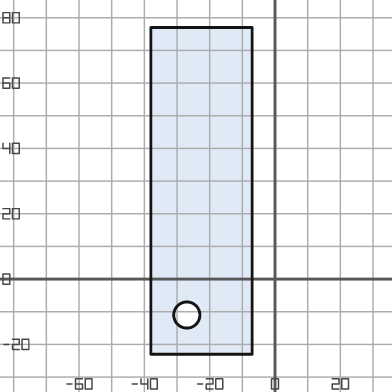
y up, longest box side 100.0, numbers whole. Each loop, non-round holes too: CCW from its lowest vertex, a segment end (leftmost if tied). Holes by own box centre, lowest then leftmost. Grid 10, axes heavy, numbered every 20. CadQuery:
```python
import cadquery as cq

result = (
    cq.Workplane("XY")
    .moveTo(-38.0, -23.0)
    .lineTo(-7.0, -23.0)
    .lineTo(-7.0, 77.0)
    .lineTo(-38.0, 77.0)
    .close()
    .moveTo(-27.0, -11.0)
    .circle(4.0)
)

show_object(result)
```